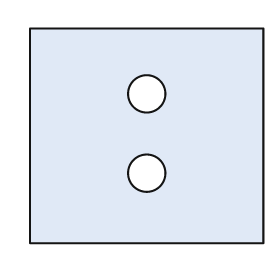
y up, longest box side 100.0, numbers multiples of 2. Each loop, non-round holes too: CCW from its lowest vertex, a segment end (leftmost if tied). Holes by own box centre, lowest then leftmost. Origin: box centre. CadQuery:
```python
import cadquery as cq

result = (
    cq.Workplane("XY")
    .moveTo(-50.0, -46.0)
    .lineTo(50.0, -46.0)
    .lineTo(50.0, 46.0)
    .lineTo(-50.0, 46.0)
    .close()
    .moveTo(0.0, -16.0)
    .circle(8.0)
    .moveTo(0.0, 18.0)
    .circle(8.0)
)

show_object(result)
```